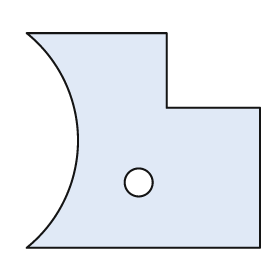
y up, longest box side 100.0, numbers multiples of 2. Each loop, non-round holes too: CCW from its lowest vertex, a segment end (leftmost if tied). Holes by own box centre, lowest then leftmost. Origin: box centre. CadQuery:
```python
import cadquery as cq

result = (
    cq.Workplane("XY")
    .moveTo(-50.0, -46.0)
    .lineTo(50.0, -46.0)
    .lineTo(50.0, 14.0)
    .lineTo(10.0, 14.0)
    .lineTo(10.0, 46.0)
    .lineTo(-50.0, 46.0)
    .threePointArc((-28.0, 0.0), (-50.0, -46.0))
    .close()
    .moveTo(-2.0, -18.0)
    .circle(6.0)
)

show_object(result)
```